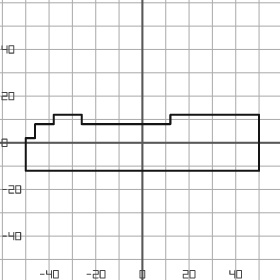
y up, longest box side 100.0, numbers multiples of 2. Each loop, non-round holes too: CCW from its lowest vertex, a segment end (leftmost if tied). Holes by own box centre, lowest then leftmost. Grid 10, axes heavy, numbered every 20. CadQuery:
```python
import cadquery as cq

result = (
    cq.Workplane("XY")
    .moveTo(-50.0, -12.0)
    .lineTo(50.0, -12.0)
    .lineTo(50.0, 12.0)
    .lineTo(12.0, 12.0)
    .lineTo(12.0, 8.0)
    .lineTo(-26.0, 8.0)
    .lineTo(-26.0, 12.0)
    .lineTo(-38.0, 12.0)
    .lineTo(-38.0, 8.0)
    .lineTo(-46.0, 8.0)
    .lineTo(-46.0, 2.0)
    .lineTo(-50.0, 2.0)
    .close()
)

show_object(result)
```